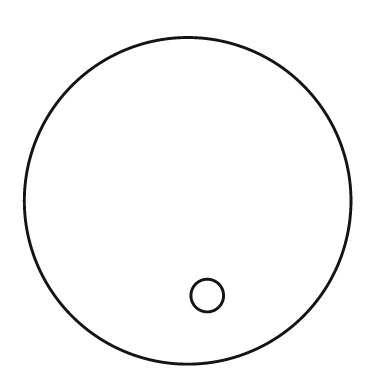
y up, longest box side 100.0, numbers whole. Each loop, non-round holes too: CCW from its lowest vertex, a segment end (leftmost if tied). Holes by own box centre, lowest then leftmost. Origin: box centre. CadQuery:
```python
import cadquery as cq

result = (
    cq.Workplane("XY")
    .moveTo(0.0, 0.0)
    .circle(50.0)
    .moveTo(6.0, -29.0)
    .circle(5.0)
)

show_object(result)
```